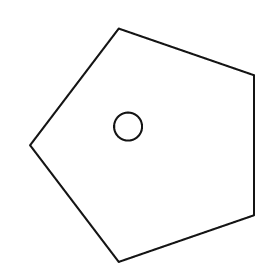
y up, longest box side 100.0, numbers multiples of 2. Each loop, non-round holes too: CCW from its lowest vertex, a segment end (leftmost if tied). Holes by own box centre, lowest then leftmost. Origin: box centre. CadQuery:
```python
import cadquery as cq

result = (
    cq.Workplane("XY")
    .moveTo(-10.0, -50.0)
    .lineTo(48.0, -30.0)
    .lineTo(48.0, 30.0)
    .lineTo(-10.0, 50.0)
    .lineTo(-48.0, 0.0)
    .close()
    .moveTo(-6.0, 8.0)
    .circle(6.0)
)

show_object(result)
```